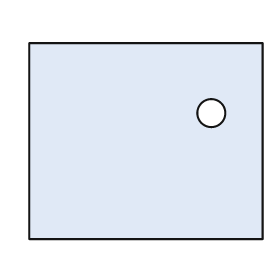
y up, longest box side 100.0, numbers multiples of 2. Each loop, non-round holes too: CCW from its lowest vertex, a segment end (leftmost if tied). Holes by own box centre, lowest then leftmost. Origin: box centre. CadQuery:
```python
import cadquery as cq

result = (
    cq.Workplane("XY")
    .moveTo(-50.0, -42.0)
    .lineTo(50.0, -42.0)
    .lineTo(50.0, 42.0)
    .lineTo(-50.0, 42.0)
    .close()
    .moveTo(28.0, 12.0)
    .circle(6.0)
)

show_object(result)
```